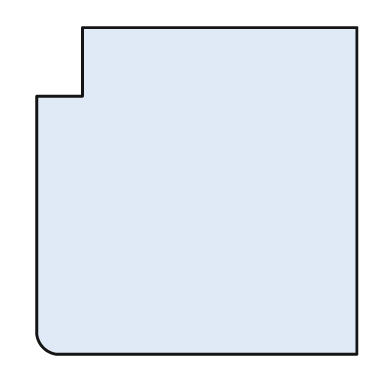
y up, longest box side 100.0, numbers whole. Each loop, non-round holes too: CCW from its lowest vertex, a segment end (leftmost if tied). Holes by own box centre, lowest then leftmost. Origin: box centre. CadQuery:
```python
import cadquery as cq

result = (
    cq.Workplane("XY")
    .moveTo(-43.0, -50.0)
    .lineTo(49.0, -50.0)
    .lineTo(49.0, 50.0)
    .lineTo(-35.0, 50.0)
    .lineTo(-35.0, 29.0)
    .lineTo(-49.0, 29.0)
    .lineTo(-49.0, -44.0)
    .threePointArc((-47.0, -48.0), (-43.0, -50.0))
    .close()
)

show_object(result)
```